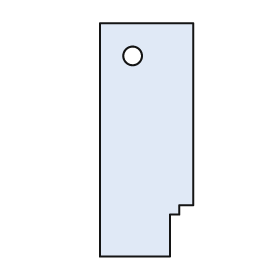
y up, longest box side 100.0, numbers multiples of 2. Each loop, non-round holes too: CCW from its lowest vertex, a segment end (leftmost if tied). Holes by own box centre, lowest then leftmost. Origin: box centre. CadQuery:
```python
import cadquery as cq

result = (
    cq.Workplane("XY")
    .moveTo(-20.0, -50.0)
    .lineTo(10.0, -50.0)
    .lineTo(10.0, -32.0)
    .lineTo(14.0, -32.0)
    .lineTo(14.0, -28.0)
    .lineTo(20.0, -28.0)
    .lineTo(20.0, 50.0)
    .lineTo(-20.0, 50.0)
    .close()
    .moveTo(-6.0, 36.0)
    .circle(4.0)
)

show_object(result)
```